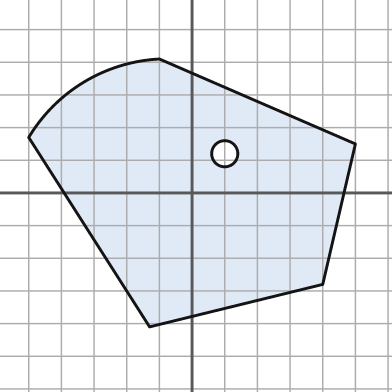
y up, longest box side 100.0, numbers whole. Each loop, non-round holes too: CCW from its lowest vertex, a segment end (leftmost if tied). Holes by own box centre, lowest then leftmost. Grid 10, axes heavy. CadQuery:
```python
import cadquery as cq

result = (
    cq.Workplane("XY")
    .moveTo(-13.0, -41.0)
    .lineTo(40.0, -28.0)
    .lineTo(50.0, 15.0)
    .lineTo(-10.0, 41.0)
    .threePointArc((-33.0, 34.0), (-50.0, 17.0))
    .close()
    .moveTo(10.0, 12.0)
    .circle(4.0)
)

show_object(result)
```